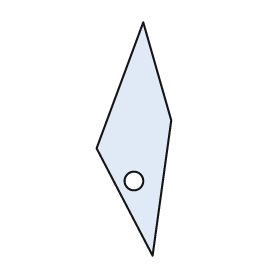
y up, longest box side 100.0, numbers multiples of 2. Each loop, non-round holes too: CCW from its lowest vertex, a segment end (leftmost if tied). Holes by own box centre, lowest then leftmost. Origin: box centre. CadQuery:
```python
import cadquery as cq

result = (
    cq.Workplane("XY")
    .moveTo(8.0, -50.0)
    .lineTo(16.0, 8.0)
    .lineTo(4.0, 50.0)
    .lineTo(-16.0, -4.0)
    .close()
    .moveTo(0.0, -18.0)
    .circle(4.0)
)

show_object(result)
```